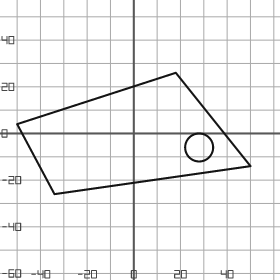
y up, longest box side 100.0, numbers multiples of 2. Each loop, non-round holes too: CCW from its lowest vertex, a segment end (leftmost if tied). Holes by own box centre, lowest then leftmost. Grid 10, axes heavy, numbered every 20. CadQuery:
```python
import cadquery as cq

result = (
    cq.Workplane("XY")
    .moveTo(-34.0, -26.0)
    .lineTo(50.0, -14.0)
    .lineTo(18.0, 26.0)
    .lineTo(-50.0, 4.0)
    .close()
    .moveTo(28.0, -6.0)
    .circle(6.0)
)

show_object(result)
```